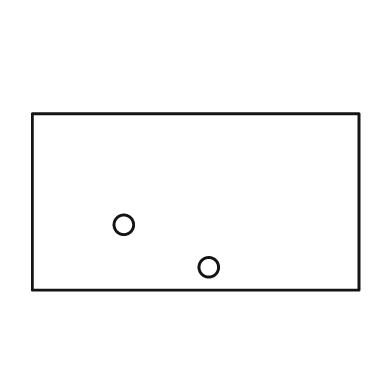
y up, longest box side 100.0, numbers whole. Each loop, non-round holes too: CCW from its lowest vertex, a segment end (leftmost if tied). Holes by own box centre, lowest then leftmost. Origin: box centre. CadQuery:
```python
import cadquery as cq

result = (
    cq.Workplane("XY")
    .moveTo(-50.0, -27.0)
    .lineTo(50.0, -27.0)
    .lineTo(50.0, 27.0)
    .lineTo(-50.0, 27.0)
    .close()
    .moveTo(4.0, -20.0)
    .circle(3.0)
    .moveTo(-22.0, -7.0)
    .circle(3.0)
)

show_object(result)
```